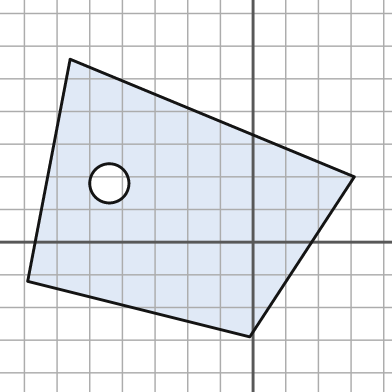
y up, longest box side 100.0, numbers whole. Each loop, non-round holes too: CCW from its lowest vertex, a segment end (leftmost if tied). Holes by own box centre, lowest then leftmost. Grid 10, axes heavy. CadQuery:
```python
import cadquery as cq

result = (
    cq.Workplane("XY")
    .moveTo(-1.0, -29.0)
    .lineTo(31.0, 20.0)
    .lineTo(-56.0, 56.0)
    .lineTo(-69.0, -12.0)
    .close()
    .moveTo(-44.0, 18.0)
    .circle(6.0)
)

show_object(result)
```